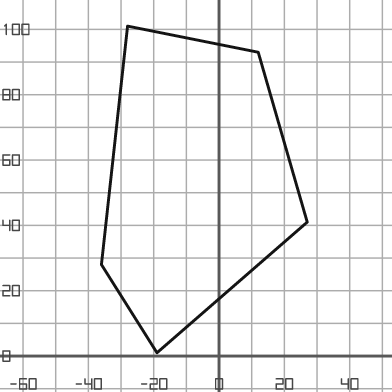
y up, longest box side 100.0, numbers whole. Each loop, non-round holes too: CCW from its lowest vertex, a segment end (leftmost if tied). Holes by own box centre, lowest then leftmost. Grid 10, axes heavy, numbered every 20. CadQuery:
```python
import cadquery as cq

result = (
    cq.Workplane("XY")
    .moveTo(-19.0, 1.0)
    .lineTo(27.0, 41.0)
    .lineTo(12.0, 93.0)
    .lineTo(-28.0, 101.0)
    .lineTo(-36.0, 28.0)
    .close()
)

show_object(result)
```